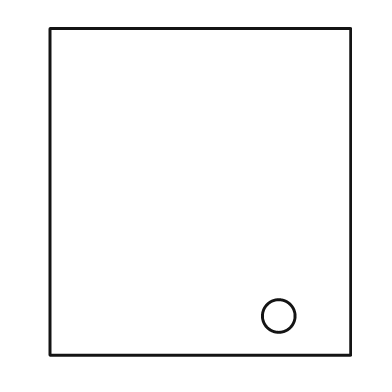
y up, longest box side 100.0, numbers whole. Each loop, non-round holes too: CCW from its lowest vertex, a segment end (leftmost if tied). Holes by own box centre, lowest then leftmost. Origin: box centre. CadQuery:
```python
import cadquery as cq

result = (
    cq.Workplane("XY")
    .moveTo(-46.0, -50.0)
    .lineTo(46.0, -50.0)
    .lineTo(46.0, 50.0)
    .lineTo(-46.0, 50.0)
    .close()
    .moveTo(24.0, -38.0)
    .circle(5.0)
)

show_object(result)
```